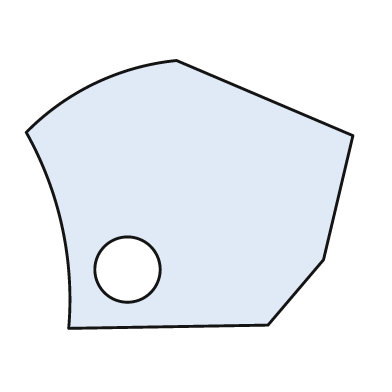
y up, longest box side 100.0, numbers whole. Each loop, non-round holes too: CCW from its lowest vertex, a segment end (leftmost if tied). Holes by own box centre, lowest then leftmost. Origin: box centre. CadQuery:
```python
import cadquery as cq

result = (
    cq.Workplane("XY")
    .moveTo(-37.0, -41.0)
    .lineTo(24.0, -40.0)
    .lineTo(41.0, -20.0)
    .lineTo(50.0, 18.0)
    .lineTo(-4.0, 41.0)
    .threePointArc((-29.0, 34.0), (-50.0, 19.0))
    .threePointArc((-39.0, -10.0), (-37.0, -41.0))
    .close()
    .moveTo(-19.0, -23.0)
    .circle(10.0)
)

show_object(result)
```